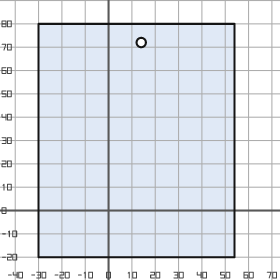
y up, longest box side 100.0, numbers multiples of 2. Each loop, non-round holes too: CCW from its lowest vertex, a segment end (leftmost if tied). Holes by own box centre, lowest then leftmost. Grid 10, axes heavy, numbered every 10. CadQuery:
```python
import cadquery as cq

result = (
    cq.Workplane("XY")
    .moveTo(-30.0, -20.0)
    .lineTo(54.0, -20.0)
    .lineTo(54.0, 80.0)
    .lineTo(-30.0, 80.0)
    .close()
    .moveTo(14.0, 72.0)
    .circle(2.0)
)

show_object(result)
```